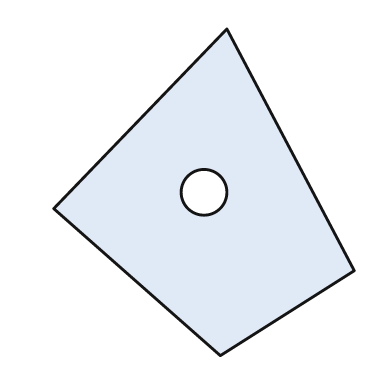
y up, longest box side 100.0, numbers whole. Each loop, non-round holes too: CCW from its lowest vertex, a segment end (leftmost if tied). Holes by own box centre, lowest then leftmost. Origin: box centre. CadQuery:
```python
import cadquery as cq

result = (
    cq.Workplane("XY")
    .moveTo(5.0, -50.0)
    .lineTo(46.0, -24.0)
    .lineTo(7.0, 50.0)
    .lineTo(-46.0, -5.0)
    .close()
    .moveTo(0.0, 0.0)
    .circle(7.0)
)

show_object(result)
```